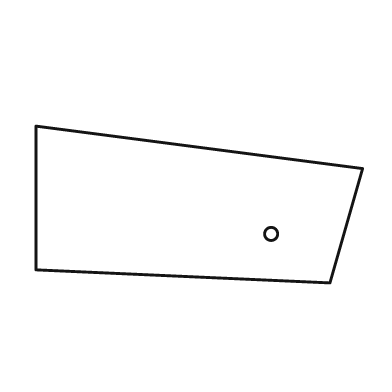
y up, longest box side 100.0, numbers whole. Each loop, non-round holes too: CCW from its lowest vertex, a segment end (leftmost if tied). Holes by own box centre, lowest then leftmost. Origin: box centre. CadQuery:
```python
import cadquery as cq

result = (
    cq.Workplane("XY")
    .moveTo(40.0, -24.0)
    .lineTo(50.0, 11.0)
    .lineTo(-50.0, 24.0)
    .lineTo(-50.0, -20.0)
    .close()
    .moveTo(22.0, -9.0)
    .circle(2.0)
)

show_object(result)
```